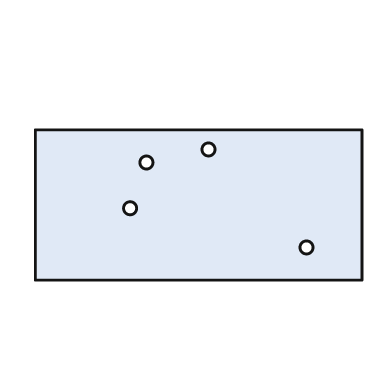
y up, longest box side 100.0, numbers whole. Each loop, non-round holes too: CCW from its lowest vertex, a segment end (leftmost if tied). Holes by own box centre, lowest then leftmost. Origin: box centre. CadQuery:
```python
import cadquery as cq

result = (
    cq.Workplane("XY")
    .moveTo(-50.0, -23.0)
    .lineTo(50.0, -23.0)
    .lineTo(50.0, 23.0)
    .lineTo(-50.0, 23.0)
    .close()
    .moveTo(33.0, -13.0)
    .circle(2.0)
    .moveTo(-21.0, -1.0)
    .circle(2.0)
    .moveTo(-16.0, 13.0)
    .circle(2.0)
    .moveTo(3.0, 17.0)
    .circle(2.0)
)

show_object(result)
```